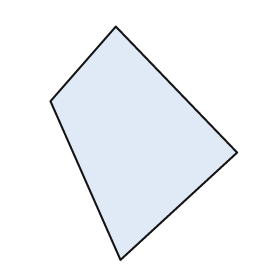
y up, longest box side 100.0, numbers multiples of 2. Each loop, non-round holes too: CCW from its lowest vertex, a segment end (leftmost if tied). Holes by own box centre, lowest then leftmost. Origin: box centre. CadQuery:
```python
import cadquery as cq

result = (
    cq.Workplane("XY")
    .moveTo(-10.0, -50.0)
    .lineTo(40.0, -4.0)
    .lineTo(-12.0, 50.0)
    .lineTo(-40.0, 18.0)
    .close()
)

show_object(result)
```